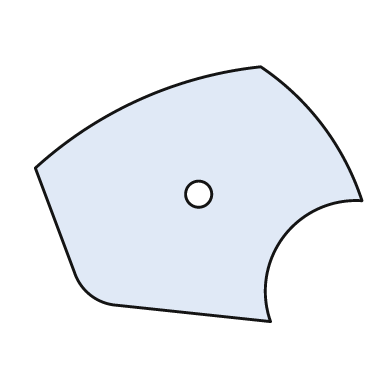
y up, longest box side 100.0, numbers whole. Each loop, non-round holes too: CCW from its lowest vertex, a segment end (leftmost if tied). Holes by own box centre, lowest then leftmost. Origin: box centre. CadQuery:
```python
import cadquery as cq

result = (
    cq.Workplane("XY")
    .moveTo(22.0, -39.0)
    .threePointArc((26.0, -13.0), (50.0, -2.0))
    .threePointArc((38.0, 21.0), (19.0, 39.0))
    .threePointArc((-18.0, 29.0), (-50.0, 8.0))
    .lineTo(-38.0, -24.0)
    .threePointArc((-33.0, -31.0), (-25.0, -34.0))
    .close()
    .moveTo(0.0, 0.0)
    .circle(4.0)
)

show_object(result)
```